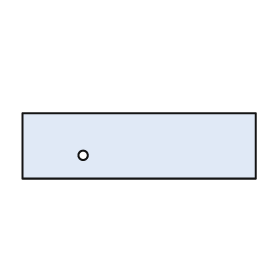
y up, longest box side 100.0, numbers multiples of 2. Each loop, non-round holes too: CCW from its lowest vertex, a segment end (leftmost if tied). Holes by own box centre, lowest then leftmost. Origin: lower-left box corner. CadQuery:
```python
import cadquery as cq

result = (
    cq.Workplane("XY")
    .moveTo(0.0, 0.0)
    .lineTo(100.0, 0.0)
    .lineTo(100.0, 28.0)
    .lineTo(0.0, 28.0)
    .close()
    .moveTo(26.0, 10.0)
    .circle(2.0)
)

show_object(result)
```